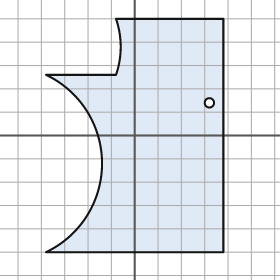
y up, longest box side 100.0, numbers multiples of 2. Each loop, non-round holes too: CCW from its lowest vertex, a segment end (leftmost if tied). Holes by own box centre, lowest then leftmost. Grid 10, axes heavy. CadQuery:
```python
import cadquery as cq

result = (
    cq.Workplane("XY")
    .moveTo(-38.0, -50.0)
    .lineTo(38.0, -50.0)
    .lineTo(38.0, 50.0)
    .lineTo(-8.0, 50.0)
    .threePointArc((-6.0, 38.0), (-8.0, 26.0))
    .lineTo(-38.0, 26.0)
    .threePointArc((-14.0, -12.0), (-38.0, -50.0))
    .close()
    .moveTo(32.0, 14.0)
    .circle(2.0)
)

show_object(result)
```